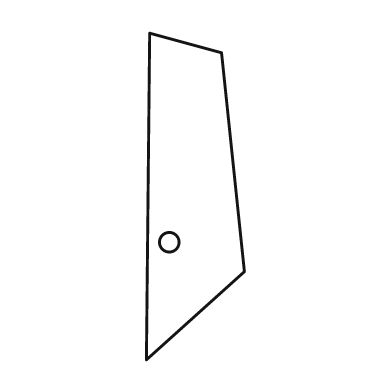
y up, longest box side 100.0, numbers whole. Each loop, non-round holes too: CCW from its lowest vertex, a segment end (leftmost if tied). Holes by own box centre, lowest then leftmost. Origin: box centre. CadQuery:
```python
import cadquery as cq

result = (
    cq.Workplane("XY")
    .moveTo(-15.0, -50.0)
    .lineTo(15.0, -23.0)
    .lineTo(8.0, 44.0)
    .lineTo(-14.0, 50.0)
    .close()
    .moveTo(-8.0, -14.0)
    .circle(3.0)
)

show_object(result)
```